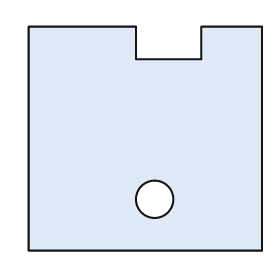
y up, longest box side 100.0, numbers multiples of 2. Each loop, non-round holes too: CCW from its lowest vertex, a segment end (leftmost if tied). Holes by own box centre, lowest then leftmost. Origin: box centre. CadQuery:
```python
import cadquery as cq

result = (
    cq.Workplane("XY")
    .moveTo(-50.0, -48.0)
    .lineTo(50.0, -48.0)
    .lineTo(50.0, 48.0)
    .lineTo(24.0, 48.0)
    .lineTo(24.0, 34.0)
    .lineTo(-4.0, 34.0)
    .lineTo(-4.0, 48.0)
    .lineTo(-50.0, 48.0)
    .close()
    .moveTo(4.0, -26.0)
    .circle(8.0)
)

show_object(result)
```